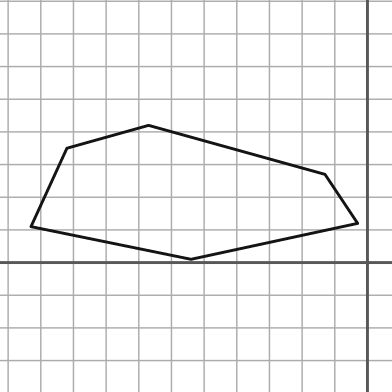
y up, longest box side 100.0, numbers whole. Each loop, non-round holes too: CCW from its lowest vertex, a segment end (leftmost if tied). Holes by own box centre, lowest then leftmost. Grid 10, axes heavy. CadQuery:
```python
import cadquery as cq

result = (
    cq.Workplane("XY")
    .moveTo(-54.0, 1.0)
    .lineTo(-3.0, 12.0)
    .lineTo(-13.0, 27.0)
    .lineTo(-67.0, 42.0)
    .lineTo(-92.0, 35.0)
    .lineTo(-103.0, 11.0)
    .close()
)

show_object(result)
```